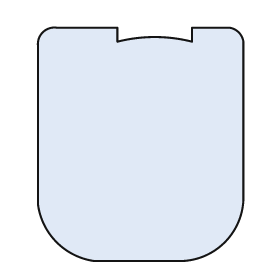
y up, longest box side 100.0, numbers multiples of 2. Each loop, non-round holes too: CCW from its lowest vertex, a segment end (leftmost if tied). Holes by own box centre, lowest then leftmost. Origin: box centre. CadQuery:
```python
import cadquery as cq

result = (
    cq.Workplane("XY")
    .moveTo(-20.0, -50.0)
    .lineTo(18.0, -50.0)
    .threePointArc((36.0, -42.0), (44.0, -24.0))
    .lineTo(44.0, 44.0)
    .threePointArc((42.0, 48.0), (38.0, 50.0))
    .lineTo(22.0, 50.0)
    .lineTo(22.0, 44.0)
    .threePointArc((6.0, 46.0), (-10.0, 44.0))
    .lineTo(-10.0, 50.0)
    .lineTo(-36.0, 50.0)
    .threePointArc((-42.0, 48.0), (-44.0, 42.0))
    .lineTo(-44.0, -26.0)
    .threePointArc((-36.0, -42.0), (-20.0, -50.0))
    .close()
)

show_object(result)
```